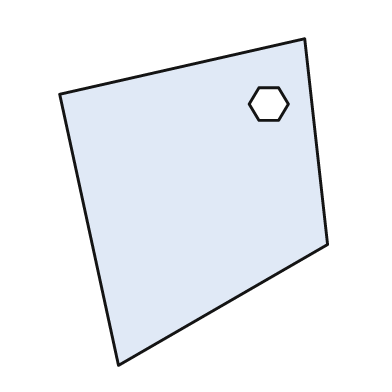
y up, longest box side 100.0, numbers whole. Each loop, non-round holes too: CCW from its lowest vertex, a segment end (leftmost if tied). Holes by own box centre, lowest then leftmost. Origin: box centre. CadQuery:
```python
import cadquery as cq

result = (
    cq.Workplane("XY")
    .moveTo(-23.0, -50.0)
    .lineTo(41.0, -13.0)
    .lineTo(34.0, 50.0)
    .lineTo(-41.0, 33.0)
    .close()
    .moveTo(20.0, 25.0)
    .lineTo(26.0, 25.0)
    .lineTo(29.0, 30.0)
    .lineTo(26.0, 35.0)
    .lineTo(20.0, 35.0)
    .lineTo(17.0, 30.0)
    .close()
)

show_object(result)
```